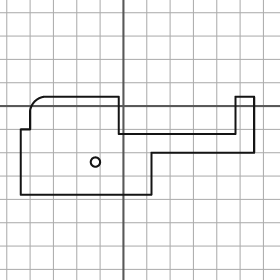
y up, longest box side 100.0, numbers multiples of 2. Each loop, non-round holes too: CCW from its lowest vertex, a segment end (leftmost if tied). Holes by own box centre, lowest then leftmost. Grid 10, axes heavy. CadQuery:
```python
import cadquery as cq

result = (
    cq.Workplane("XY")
    .moveTo(-44.0, -38.0)
    .lineTo(12.0, -38.0)
    .lineTo(12.0, -20.0)
    .lineTo(56.0, -20.0)
    .lineTo(56.0, 4.0)
    .lineTo(48.0, 4.0)
    .lineTo(48.0, -12.0)
    .lineTo(-2.0, -12.0)
    .lineTo(-2.0, 4.0)
    .lineTo(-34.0, 4.0)
    .threePointArc((-38.0, 2.0), (-40.0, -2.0))
    .lineTo(-40.0, -10.0)
    .lineTo(-44.0, -10.0)
    .close()
    .moveTo(-12.0, -24.0)
    .circle(2.0)
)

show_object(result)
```